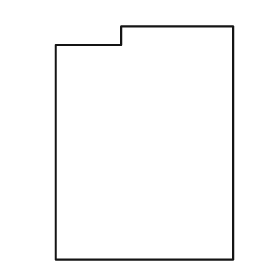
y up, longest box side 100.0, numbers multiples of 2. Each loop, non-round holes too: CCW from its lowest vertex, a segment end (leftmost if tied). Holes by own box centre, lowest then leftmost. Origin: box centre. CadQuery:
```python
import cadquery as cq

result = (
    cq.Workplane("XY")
    .moveTo(-38.0, -50.0)
    .lineTo(38.0, -50.0)
    .lineTo(38.0, 50.0)
    .lineTo(-10.0, 50.0)
    .lineTo(-10.0, 42.0)
    .lineTo(-38.0, 42.0)
    .close()
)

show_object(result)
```